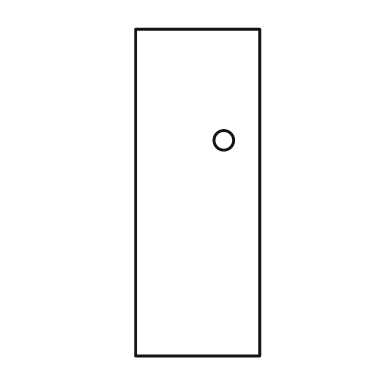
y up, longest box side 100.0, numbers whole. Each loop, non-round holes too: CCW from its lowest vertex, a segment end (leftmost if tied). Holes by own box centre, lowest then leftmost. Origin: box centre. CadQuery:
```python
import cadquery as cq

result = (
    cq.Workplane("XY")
    .moveTo(-19.0, -50.0)
    .lineTo(19.0, -50.0)
    .lineTo(19.0, 50.0)
    .lineTo(-19.0, 50.0)
    .close()
    .moveTo(8.0, 16.0)
    .circle(3.0)
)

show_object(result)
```